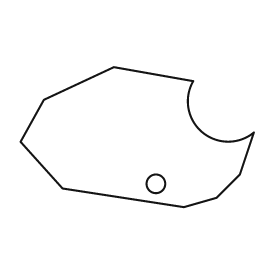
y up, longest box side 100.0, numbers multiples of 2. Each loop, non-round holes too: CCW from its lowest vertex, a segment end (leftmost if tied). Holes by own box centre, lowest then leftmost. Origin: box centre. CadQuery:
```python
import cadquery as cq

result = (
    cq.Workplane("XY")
    .moveTo(20.0, -30.0)
    .lineTo(34.0, -26.0)
    .lineTo(44.0, -16.0)
    .lineTo(50.0, 2.0)
    .threePointArc((28.0, 2.0), (24.0, 24.0))
    .lineTo(-10.0, 30.0)
    .lineTo(-40.0, 16.0)
    .lineTo(-50.0, -2.0)
    .lineTo(-32.0, -22.0)
    .close()
    .moveTo(8.0, -20.0)
    .circle(4.0)
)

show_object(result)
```